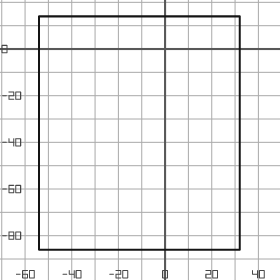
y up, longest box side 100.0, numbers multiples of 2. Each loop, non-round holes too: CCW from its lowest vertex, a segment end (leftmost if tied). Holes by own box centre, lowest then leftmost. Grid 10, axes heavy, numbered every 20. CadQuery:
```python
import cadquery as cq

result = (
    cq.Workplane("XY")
    .moveTo(-54.0, -86.0)
    .lineTo(32.0, -86.0)
    .lineTo(32.0, 14.0)
    .lineTo(-54.0, 14.0)
    .close()
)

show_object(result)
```